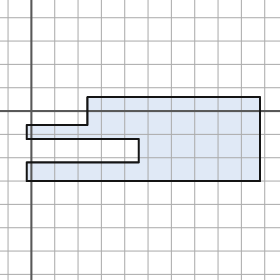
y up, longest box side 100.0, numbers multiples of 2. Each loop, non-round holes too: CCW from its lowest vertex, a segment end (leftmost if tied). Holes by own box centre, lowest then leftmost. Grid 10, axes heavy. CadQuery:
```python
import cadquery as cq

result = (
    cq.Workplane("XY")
    .moveTo(-2.0, -30.0)
    .lineTo(98.0, -30.0)
    .lineTo(98.0, 6.0)
    .lineTo(24.0, 6.0)
    .lineTo(24.0, -6.0)
    .lineTo(-2.0, -6.0)
    .lineTo(-2.0, -12.0)
    .lineTo(46.0, -12.0)
    .lineTo(46.0, -22.0)
    .lineTo(-2.0, -22.0)
    .close()
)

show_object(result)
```